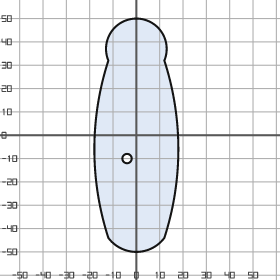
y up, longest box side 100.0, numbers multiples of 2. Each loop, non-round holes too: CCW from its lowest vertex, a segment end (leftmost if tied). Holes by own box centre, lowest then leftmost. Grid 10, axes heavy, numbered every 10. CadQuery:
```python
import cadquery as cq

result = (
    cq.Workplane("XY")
    .moveTo(-12.0, -44.0)
    .threePointArc((0.0, -50.0), (12.0, -44.0))
    .threePointArc((18.0, -6.0), (12.0, 32.0))
    .threePointArc((0.0, 50.0), (-12.0, 32.0))
    .threePointArc((-18.0, -6.0), (-12.0, -44.0))
    .close()
    .moveTo(-4.0, -10.0)
    .circle(2.0)
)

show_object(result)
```